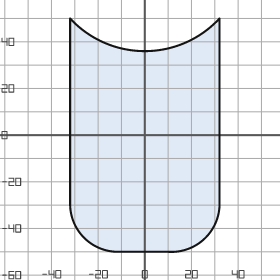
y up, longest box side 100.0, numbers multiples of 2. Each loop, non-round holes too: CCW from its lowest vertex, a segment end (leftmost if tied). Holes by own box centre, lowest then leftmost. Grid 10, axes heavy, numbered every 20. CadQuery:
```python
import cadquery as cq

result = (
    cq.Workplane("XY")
    .moveTo(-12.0, -50.0)
    .lineTo(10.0, -50.0)
    .threePointArc((26.0, -44.0), (32.0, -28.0))
    .lineTo(32.0, 50.0)
    .threePointArc((0.0, 36.0), (-32.0, 50.0))
    .lineTo(-32.0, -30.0)
    .threePointArc((-26.0, -44.0), (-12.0, -50.0))
    .close()
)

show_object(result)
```